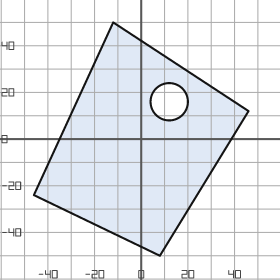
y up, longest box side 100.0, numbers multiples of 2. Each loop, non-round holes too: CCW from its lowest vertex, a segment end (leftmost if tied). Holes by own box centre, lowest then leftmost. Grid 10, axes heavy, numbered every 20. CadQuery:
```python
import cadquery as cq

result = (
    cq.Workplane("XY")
    .moveTo(8.0, -50.0)
    .lineTo(46.0, 12.0)
    .lineTo(-12.0, 50.0)
    .lineTo(-46.0, -24.0)
    .close()
    .moveTo(12.0, 16.0)
    .circle(8.0)
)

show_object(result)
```